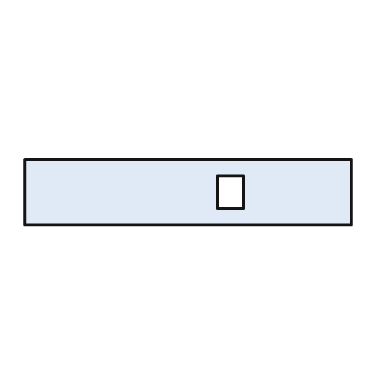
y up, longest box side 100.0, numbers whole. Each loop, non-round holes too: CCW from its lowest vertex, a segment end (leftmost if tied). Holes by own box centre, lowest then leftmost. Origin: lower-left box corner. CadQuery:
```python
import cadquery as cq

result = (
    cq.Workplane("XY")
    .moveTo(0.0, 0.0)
    .lineTo(100.0, 0.0)
    .lineTo(100.0, 20.0)
    .lineTo(0.0, 20.0)
    .close()
    .moveTo(59.0, 5.0)
    .lineTo(67.0, 5.0)
    .lineTo(67.0, 15.0)
    .lineTo(59.0, 15.0)
    .close()
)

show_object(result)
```